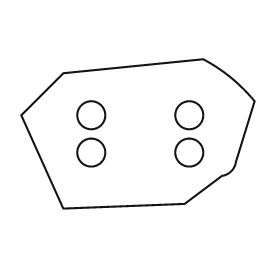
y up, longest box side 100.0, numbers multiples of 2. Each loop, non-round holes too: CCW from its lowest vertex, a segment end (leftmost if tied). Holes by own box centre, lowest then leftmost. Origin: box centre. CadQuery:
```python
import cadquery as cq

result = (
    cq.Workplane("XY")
    .moveTo(-32.0, -32.0)
    .lineTo(20.0, -30.0)
    .lineTo(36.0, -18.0)
    .threePointArc((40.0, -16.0), (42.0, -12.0))
    .lineTo(50.0, 14.0)
    .threePointArc((40.0, 24.0), (28.0, 32.0))
    .lineTo(-32.0, 26.0)
    .lineTo(-50.0, 8.0)
    .close()
    .moveTo(-20.0, -8.0)
    .circle(6.0)
    .moveTo(22.0, -8.0)
    .circle(6.0)
    .moveTo(-20.0, 8.0)
    .circle(6.0)
    .moveTo(22.0, 8.0)
    .circle(6.0)
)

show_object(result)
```